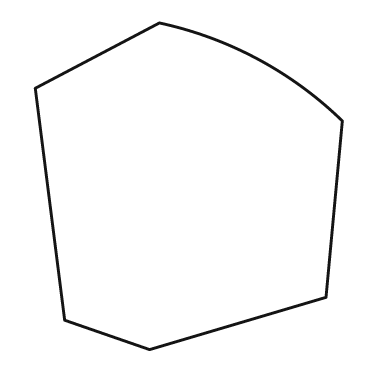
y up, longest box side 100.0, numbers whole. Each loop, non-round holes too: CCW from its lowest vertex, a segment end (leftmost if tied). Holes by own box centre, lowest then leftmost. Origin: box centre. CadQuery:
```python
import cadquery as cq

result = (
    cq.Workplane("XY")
    .moveTo(-12.0, -50.0)
    .lineTo(42.0, -34.0)
    .lineTo(47.0, 20.0)
    .threePointArc((21.0, 39.0), (-9.0, 50.0))
    .lineTo(-47.0, 30.0)
    .lineTo(-38.0, -41.0)
    .close()
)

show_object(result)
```